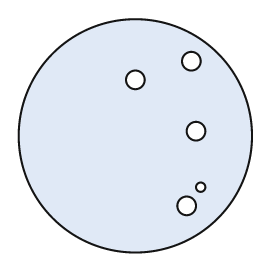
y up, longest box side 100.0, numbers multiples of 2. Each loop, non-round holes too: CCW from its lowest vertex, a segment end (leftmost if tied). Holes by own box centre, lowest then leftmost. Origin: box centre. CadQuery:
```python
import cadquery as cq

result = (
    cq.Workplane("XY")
    .moveTo(0.0, 0.0)
    .circle(50.0)
    .moveTo(22.0, -30.0)
    .circle(4.0)
    .moveTo(28.0, -22.0)
    .circle(2.0)
    .moveTo(26.0, 2.0)
    .circle(4.0)
    .moveTo(0.0, 24.0)
    .circle(4.0)
    .moveTo(24.0, 32.0)
    .circle(4.0)
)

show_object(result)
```